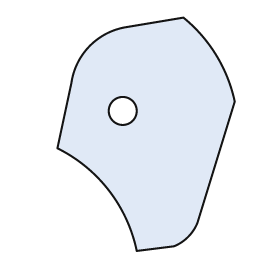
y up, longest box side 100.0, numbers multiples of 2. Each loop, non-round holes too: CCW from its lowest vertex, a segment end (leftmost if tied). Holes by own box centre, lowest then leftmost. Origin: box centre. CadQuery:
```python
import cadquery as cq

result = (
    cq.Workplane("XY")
    .moveTo(-4.0, -50.0)
    .lineTo(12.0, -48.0)
    .threePointArc((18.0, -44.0), (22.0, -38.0))
    .lineTo(38.0, 14.0)
    .threePointArc((30.0, 34.0), (16.0, 50.0))
    .lineTo(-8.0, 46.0)
    .threePointArc((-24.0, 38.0), (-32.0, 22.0))
    .lineTo(-38.0, -6.0)
    .threePointArc((-16.0, -24.0), (-4.0, -50.0))
    .close()
    .moveTo(-10.0, 10.0)
    .circle(6.0)
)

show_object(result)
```